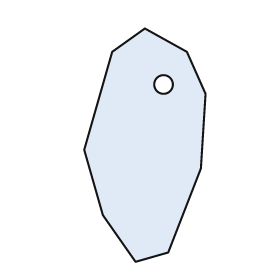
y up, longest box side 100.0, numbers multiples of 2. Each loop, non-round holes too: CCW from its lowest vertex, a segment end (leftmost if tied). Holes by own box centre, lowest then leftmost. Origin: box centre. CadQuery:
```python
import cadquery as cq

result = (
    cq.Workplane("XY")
    .moveTo(-4.0, -50.0)
    .lineTo(10.0, -46.0)
    .lineTo(24.0, -10.0)
    .lineTo(26.0, 22.0)
    .lineTo(18.0, 40.0)
    .lineTo(0.0, 50.0)
    .lineTo(-14.0, 40.0)
    .lineTo(-26.0, -2.0)
    .lineTo(-18.0, -30.0)
    .close()
    .moveTo(8.0, 26.0)
    .circle(4.0)
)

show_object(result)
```